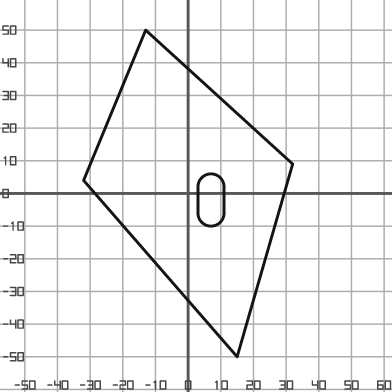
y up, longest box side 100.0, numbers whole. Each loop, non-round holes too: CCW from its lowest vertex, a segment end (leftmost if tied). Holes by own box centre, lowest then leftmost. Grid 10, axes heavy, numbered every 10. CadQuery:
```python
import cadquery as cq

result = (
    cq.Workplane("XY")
    .moveTo(15.0, -50.0)
    .lineTo(32.0, 9.0)
    .lineTo(-13.0, 50.0)
    .lineTo(-32.0, 4.0)
    .close()
    .moveTo(3.0, -6.0)
    .threePointArc((7.0, -10.0), (11.0, -6.0))
    .lineTo(11.0, 2.0)
    .threePointArc((7.0, 6.0), (3.0, 2.0))
    .close()
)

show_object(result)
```